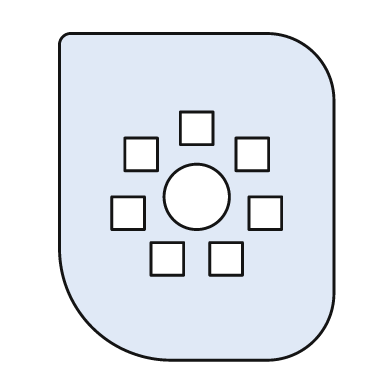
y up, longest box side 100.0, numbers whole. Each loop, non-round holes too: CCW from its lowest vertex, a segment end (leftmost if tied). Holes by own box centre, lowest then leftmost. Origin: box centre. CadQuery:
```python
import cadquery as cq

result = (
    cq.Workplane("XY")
    .moveTo(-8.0, -50.0)
    .lineTo(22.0, -50.0)
    .threePointArc((36.0, -44.0), (42.0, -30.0))
    .lineTo(42.0, 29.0)
    .threePointArc((36.0, 44.0), (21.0, 50.0))
    .lineTo(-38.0, 50.0)
    .threePointArc((-41.0, 49.0), (-42.0, 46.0))
    .lineTo(-42.0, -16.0)
    .threePointArc((-32.0, -40.0), (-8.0, -50.0))
    .close()
    .moveTo(-14.0, -24.0)
    .lineTo(-4.0, -24.0)
    .lineTo(-4.0, -14.0)
    .lineTo(-14.0, -14.0)
    .close()
    .moveTo(4.0, -24.0)
    .lineTo(14.0, -24.0)
    .lineTo(14.0, -14.0)
    .lineTo(4.0, -14.0)
    .close()
    .moveTo(-26.0, -10.0)
    .lineTo(-16.0, -10.0)
    .lineTo(-16.0, 0.0)
    .lineTo(-26.0, 0.0)
    .close()
    .moveTo(16.0, -10.0)
    .lineTo(26.0, -10.0)
    .lineTo(26.0, 0.0)
    .lineTo(16.0, 0.0)
    .close()
    .moveTo(0.0, 0.0)
    .circle(10.0)
    .moveTo(-22.0, 8.0)
    .lineTo(-12.0, 8.0)
    .lineTo(-12.0, 18.0)
    .lineTo(-22.0, 18.0)
    .close()
    .moveTo(12.0, 8.0)
    .lineTo(22.0, 8.0)
    .lineTo(22.0, 18.0)
    .lineTo(12.0, 18.0)
    .close()
    .moveTo(-5.0, 16.0)
    .lineTo(5.0, 16.0)
    .lineTo(5.0, 26.0)
    .lineTo(-5.0, 26.0)
    .close()
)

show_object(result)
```